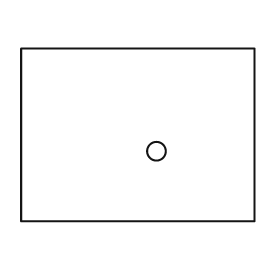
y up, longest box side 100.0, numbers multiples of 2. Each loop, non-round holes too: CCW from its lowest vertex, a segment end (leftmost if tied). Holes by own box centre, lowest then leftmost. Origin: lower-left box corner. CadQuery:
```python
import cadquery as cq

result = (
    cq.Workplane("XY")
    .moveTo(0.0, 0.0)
    .lineTo(100.0, 0.0)
    .lineTo(100.0, 74.0)
    .lineTo(0.0, 74.0)
    .close()
    .moveTo(58.0, 30.0)
    .circle(4.0)
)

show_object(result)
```